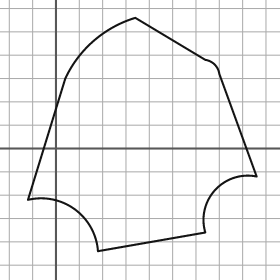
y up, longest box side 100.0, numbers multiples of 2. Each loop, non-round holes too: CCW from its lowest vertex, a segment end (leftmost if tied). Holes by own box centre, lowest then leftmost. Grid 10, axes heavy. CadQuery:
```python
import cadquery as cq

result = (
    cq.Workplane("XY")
    .moveTo(18.0, -44.0)
    .lineTo(64.0, -36.0)
    .threePointArc((68.0, -18.0), (86.0, -12.0))
    .lineTo(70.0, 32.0)
    .threePointArc((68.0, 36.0), (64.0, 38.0))
    .lineTo(34.0, 56.0)
    .threePointArc((16.0, 46.0), (4.0, 30.0))
    .lineTo(-12.0, -22.0)
    .threePointArc((8.0, -26.0), (18.0, -44.0))
    .close()
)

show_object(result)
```